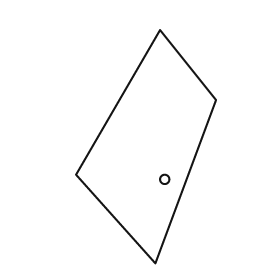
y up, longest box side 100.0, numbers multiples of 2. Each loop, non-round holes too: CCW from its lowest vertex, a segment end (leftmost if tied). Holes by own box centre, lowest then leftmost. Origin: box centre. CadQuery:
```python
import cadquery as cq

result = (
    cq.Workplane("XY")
    .moveTo(4.0, -50.0)
    .lineTo(30.0, 20.0)
    .lineTo(6.0, 50.0)
    .lineTo(-30.0, -12.0)
    .close()
    .moveTo(8.0, -14.0)
    .circle(2.0)
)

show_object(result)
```